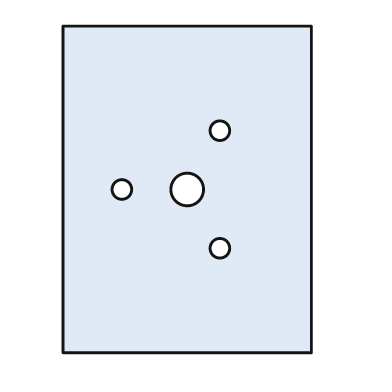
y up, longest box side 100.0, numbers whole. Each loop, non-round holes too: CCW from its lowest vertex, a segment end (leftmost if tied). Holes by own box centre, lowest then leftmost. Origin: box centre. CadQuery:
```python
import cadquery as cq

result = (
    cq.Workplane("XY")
    .moveTo(-38.0, -50.0)
    .lineTo(38.0, -50.0)
    .lineTo(38.0, 50.0)
    .lineTo(-38.0, 50.0)
    .close()
    .moveTo(10.0, -18.0)
    .circle(3.0)
    .moveTo(-20.0, 0.0)
    .circle(3.0)
    .moveTo(0.0, 0.0)
    .circle(5.0)
    .moveTo(10.0, 18.0)
    .circle(3.0)
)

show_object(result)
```